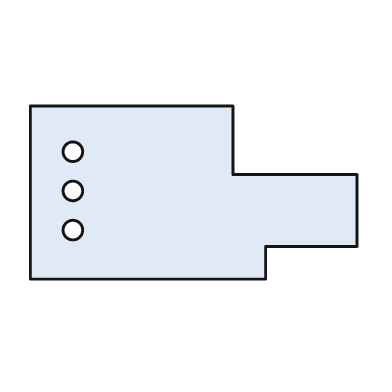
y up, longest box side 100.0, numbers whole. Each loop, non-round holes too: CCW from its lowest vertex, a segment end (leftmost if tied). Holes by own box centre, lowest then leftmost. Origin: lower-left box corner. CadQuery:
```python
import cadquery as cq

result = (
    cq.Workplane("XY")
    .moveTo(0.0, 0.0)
    .lineTo(72.0, 0.0)
    .lineTo(72.0, 10.0)
    .lineTo(100.0, 10.0)
    .lineTo(100.0, 32.0)
    .lineTo(62.0, 32.0)
    .lineTo(62.0, 53.0)
    .lineTo(0.0, 53.0)
    .close()
    .moveTo(13.0, 15.0)
    .circle(3.0)
    .moveTo(13.0, 27.0)
    .circle(3.0)
    .moveTo(13.0, 39.0)
    .circle(3.0)
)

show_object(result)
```